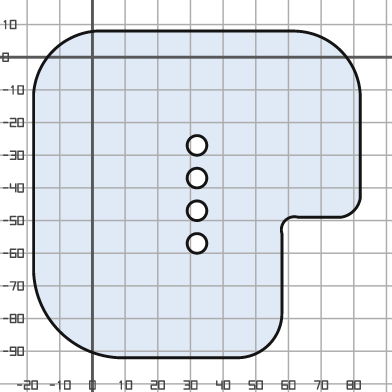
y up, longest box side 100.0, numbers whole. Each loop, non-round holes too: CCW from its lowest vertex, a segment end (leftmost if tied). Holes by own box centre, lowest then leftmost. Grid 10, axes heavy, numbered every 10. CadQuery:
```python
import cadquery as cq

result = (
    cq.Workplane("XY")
    .moveTo(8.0, -92.0)
    .lineTo(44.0, -92.0)
    .threePointArc((54.0, -88.0), (58.0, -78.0))
    .lineTo(58.0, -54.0)
    .threePointArc((59.0, -50.0), (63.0, -49.0))
    .lineTo(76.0, -49.0)
    .threePointArc((80.0, -47.0), (82.0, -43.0))
    .lineTo(82.0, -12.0)
    .threePointArc((76.0, 2.0), (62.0, 8.0))
    .lineTo(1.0, 8.0)
    .threePointArc((-12.0, 2.0), (-18.0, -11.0))
    .lineTo(-18.0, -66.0)
    .threePointArc((-10.0, -84.0), (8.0, -92.0))
    .close()
    .moveTo(32.0, -57.0)
    .circle(3.0)
    .moveTo(32.0, -47.0)
    .circle(3.0)
    .moveTo(32.0, -37.0)
    .circle(3.0)
    .moveTo(32.0, -27.0)
    .circle(3.0)
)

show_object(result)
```